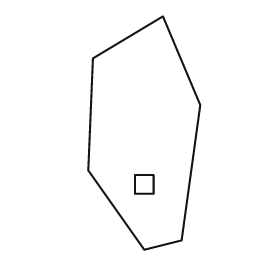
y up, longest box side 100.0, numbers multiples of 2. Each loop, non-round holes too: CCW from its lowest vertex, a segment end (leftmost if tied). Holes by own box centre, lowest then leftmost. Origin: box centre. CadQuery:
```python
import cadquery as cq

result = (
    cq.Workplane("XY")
    .moveTo(0.0, -50.0)
    .lineTo(16.0, -46.0)
    .lineTo(24.0, 12.0)
    .lineTo(8.0, 50.0)
    .lineTo(-22.0, 32.0)
    .lineTo(-24.0, -16.0)
    .close()
    .moveTo(-4.0, -26.0)
    .lineTo(4.0, -26.0)
    .lineTo(4.0, -18.0)
    .lineTo(-4.0, -18.0)
    .close()
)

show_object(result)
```